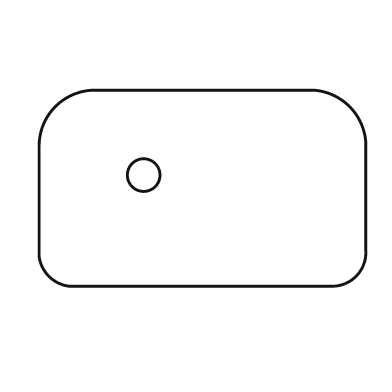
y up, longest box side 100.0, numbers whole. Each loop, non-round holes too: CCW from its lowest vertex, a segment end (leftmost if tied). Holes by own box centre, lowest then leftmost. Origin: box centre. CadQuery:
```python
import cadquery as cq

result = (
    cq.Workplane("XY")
    .moveTo(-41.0, -30.0)
    .lineTo(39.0, -30.0)
    .threePointArc((47.0, -27.0), (50.0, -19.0))
    .lineTo(50.0, 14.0)
    .threePointArc((45.0, 25.0), (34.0, 30.0))
    .lineTo(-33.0, 30.0)
    .threePointArc((-45.0, 25.0), (-50.0, 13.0))
    .lineTo(-50.0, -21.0)
    .threePointArc((-47.0, -27.0), (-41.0, -30.0))
    .close()
    .moveTo(-18.0, 4.0)
    .circle(5.0)
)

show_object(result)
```